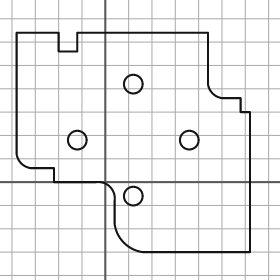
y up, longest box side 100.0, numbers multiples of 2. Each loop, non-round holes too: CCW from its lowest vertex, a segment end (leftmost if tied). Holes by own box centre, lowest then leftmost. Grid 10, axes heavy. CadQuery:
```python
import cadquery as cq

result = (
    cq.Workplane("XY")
    .moveTo(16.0, -30.0)
    .lineTo(62.0, -30.0)
    .lineTo(62.0, 30.0)
    .lineTo(58.0, 30.0)
    .lineTo(58.0, 36.0)
    .lineTo(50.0, 36.0)
    .threePointArc((46.0, 38.0), (44.0, 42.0))
    .lineTo(44.0, 64.0)
    .lineTo(-12.0, 64.0)
    .lineTo(-12.0, 56.0)
    .lineTo(-20.0, 56.0)
    .lineTo(-20.0, 64.0)
    .lineTo(-38.0, 64.0)
    .lineTo(-38.0, 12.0)
    .threePointArc((-36.0, 8.0), (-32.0, 6.0))
    .lineTo(-22.0, 6.0)
    .lineTo(-22.0, 0.0)
    .lineTo(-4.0, 0.0)
    .threePointArc((2.0, -2.0), (4.0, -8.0))
    .lineTo(4.0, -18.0)
    .threePointArc((8.0, -26.0), (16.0, -30.0))
    .close()
    .moveTo(12.0, -6.0)
    .circle(4.0)
    .moveTo(-12.0, 18.0)
    .circle(4.0)
    .moveTo(36.0, 18.0)
    .circle(4.0)
    .moveTo(12.0, 42.0)
    .circle(4.0)
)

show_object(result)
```